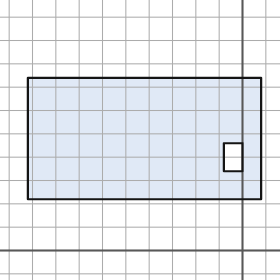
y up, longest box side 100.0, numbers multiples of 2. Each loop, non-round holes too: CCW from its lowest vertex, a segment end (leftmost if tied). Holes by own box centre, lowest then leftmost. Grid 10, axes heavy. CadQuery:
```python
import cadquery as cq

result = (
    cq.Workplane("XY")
    .moveTo(-92.0, 22.0)
    .lineTo(8.0, 22.0)
    .lineTo(8.0, 74.0)
    .lineTo(-92.0, 74.0)
    .close()
    .moveTo(-8.0, 34.0)
    .lineTo(0.0, 34.0)
    .lineTo(0.0, 46.0)
    .lineTo(-8.0, 46.0)
    .close()
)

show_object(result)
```